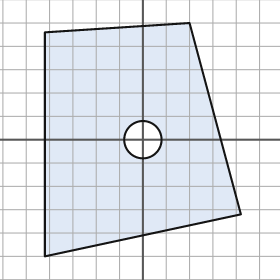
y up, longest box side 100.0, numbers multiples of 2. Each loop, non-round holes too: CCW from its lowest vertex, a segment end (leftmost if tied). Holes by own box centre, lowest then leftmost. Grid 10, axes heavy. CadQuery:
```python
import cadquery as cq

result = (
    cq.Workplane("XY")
    .moveTo(-42.0, -50.0)
    .lineTo(42.0, -32.0)
    .lineTo(20.0, 50.0)
    .lineTo(-42.0, 46.0)
    .close()
    .moveTo(0.0, 0.0)
    .circle(8.0)
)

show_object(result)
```